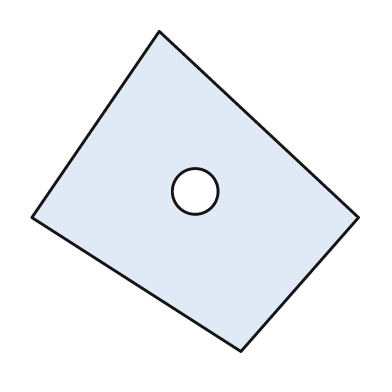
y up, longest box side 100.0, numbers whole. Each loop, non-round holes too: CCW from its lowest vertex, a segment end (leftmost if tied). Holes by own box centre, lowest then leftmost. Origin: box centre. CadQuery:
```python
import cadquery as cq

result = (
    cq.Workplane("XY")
    .moveTo(14.0, -49.0)
    .lineTo(50.0, -8.0)
    .lineTo(-11.0, 49.0)
    .lineTo(-50.0, -8.0)
    .close()
    .moveTo(0.0, 0.0)
    .circle(7.0)
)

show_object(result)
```